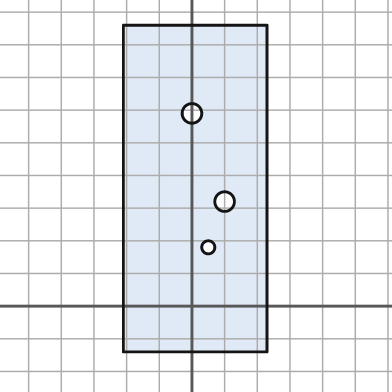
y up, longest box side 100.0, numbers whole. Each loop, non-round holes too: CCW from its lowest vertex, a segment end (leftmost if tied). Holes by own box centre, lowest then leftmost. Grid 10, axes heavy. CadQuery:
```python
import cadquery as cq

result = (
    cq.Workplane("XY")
    .moveTo(-21.0, -14.0)
    .lineTo(23.0, -14.0)
    .lineTo(23.0, 86.0)
    .lineTo(-21.0, 86.0)
    .close()
    .moveTo(5.0, 18.0)
    .circle(2.0)
    .moveTo(10.0, 32.0)
    .circle(3.0)
    .moveTo(0.0, 59.0)
    .circle(3.0)
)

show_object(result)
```